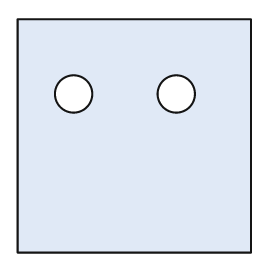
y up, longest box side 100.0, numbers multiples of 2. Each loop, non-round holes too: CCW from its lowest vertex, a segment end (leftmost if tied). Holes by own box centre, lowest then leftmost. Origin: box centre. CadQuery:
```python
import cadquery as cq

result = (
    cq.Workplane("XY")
    .moveTo(-50.0, -50.0)
    .lineTo(50.0, -50.0)
    .lineTo(50.0, 50.0)
    .lineTo(-50.0, 50.0)
    .close()
    .moveTo(-26.0, 18.0)
    .circle(8.0)
    .moveTo(18.0, 18.0)
    .circle(8.0)
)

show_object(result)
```